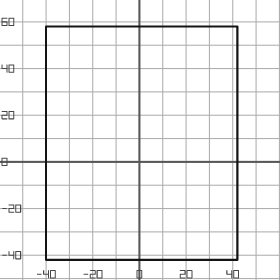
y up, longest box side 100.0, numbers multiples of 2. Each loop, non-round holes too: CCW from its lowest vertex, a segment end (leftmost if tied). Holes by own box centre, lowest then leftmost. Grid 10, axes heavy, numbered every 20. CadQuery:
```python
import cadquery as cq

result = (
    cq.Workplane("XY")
    .moveTo(-40.0, -42.0)
    .lineTo(42.0, -42.0)
    .lineTo(42.0, 58.0)
    .lineTo(-40.0, 58.0)
    .close()
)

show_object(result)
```